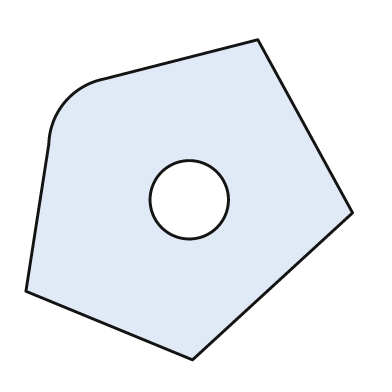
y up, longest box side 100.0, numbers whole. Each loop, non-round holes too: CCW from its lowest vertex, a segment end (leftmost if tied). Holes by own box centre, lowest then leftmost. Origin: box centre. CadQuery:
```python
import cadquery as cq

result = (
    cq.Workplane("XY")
    .moveTo(1.0, -49.0)
    .lineTo(50.0, -4.0)
    .lineTo(21.0, 49.0)
    .lineTo(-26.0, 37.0)
    .threePointArc((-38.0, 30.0), (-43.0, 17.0))
    .lineTo(-50.0, -28.0)
    .close()
    .moveTo(0.0, 0.0)
    .circle(12.0)
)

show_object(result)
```